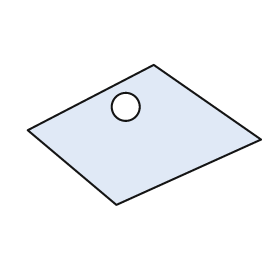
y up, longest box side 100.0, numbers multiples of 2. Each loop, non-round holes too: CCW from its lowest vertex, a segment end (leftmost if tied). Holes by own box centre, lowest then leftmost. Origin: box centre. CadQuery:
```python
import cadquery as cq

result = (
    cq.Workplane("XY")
    .moveTo(-12.0, -30.0)
    .lineTo(50.0, -2.0)
    .lineTo(4.0, 30.0)
    .lineTo(-50.0, 2.0)
    .close()
    .moveTo(-8.0, 12.0)
    .circle(6.0)
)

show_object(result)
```